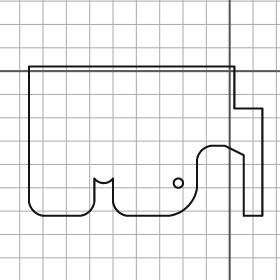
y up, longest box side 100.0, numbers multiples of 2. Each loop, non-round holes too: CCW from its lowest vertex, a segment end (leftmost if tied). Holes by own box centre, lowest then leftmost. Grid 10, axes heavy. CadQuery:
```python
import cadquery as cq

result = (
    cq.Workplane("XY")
    .moveTo(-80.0, -62.0)
    .lineTo(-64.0, -62.0)
    .threePointArc((-60.0, -60.0), (-58.0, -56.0))
    .lineTo(-58.0, -46.0)
    .threePointArc((-54.0, -48.0), (-50.0, -46.0))
    .lineTo(-50.0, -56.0)
    .threePointArc((-48.0, -60.0), (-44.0, -62.0))
    .lineTo(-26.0, -62.0)
    .threePointArc((-18.0, -58.0), (-14.0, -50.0))
    .lineTo(-14.0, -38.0)
    .threePointArc((-12.0, -34.0), (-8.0, -32.0))
    .lineTo(-2.0, -32.0)
    .lineTo(6.0, -36.0)
    .lineTo(6.0, -62.0)
    .lineTo(14.0, -62.0)
    .lineTo(14.0, -16.0)
    .lineTo(2.0, -16.0)
    .lineTo(2.0, 2.0)
    .lineTo(-86.0, 2.0)
    .lineTo(-86.0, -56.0)
    .threePointArc((-84.0, -60.0), (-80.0, -62.0))
    .close()
    .moveTo(-22.0, -48.0)
    .circle(2.0)
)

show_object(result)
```